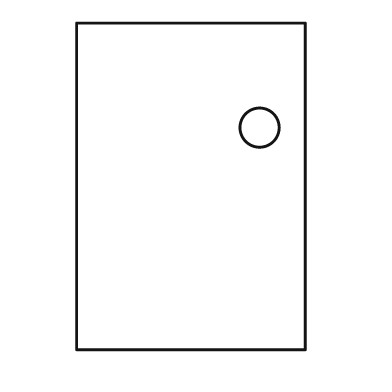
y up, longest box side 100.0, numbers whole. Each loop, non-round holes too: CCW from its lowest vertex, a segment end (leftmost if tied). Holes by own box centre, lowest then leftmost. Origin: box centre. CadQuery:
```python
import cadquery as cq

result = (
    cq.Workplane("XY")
    .moveTo(-35.0, -50.0)
    .lineTo(35.0, -50.0)
    .lineTo(35.0, 50.0)
    .lineTo(-35.0, 50.0)
    .close()
    .moveTo(21.0, 18.0)
    .circle(6.0)
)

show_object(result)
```